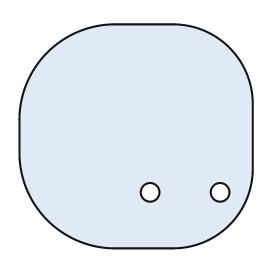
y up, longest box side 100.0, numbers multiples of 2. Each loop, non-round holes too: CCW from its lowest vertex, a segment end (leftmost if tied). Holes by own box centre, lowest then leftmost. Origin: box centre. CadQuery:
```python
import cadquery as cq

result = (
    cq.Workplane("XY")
    .moveTo(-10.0, -48.0)
    .lineTo(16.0, -48.0)
    .threePointArc((40.0, -38.0), (50.0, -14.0))
    .lineTo(50.0, 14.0)
    .threePointArc((40.0, 38.0), (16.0, 48.0))
    .lineTo(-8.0, 48.0)
    .threePointArc((-38.0, 36.0), (-50.0, 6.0))
    .lineTo(-50.0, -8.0)
    .threePointArc((-38.0, -36.0), (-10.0, -48.0))
    .close()
    .moveTo(6.0, -24.0)
    .circle(4.0)
    .moveTo(36.0, -24.0)
    .circle(4.0)
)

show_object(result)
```